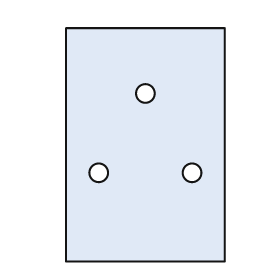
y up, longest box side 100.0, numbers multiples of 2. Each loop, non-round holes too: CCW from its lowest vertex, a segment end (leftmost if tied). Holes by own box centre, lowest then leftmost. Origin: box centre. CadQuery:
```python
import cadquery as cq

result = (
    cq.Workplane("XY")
    .moveTo(-34.0, -50.0)
    .lineTo(34.0, -50.0)
    .lineTo(34.0, 50.0)
    .lineTo(-34.0, 50.0)
    .close()
    .moveTo(-20.0, -12.0)
    .circle(4.0)
    .moveTo(20.0, -12.0)
    .circle(4.0)
    .moveTo(0.0, 22.0)
    .circle(4.0)
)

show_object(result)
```